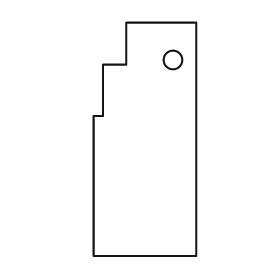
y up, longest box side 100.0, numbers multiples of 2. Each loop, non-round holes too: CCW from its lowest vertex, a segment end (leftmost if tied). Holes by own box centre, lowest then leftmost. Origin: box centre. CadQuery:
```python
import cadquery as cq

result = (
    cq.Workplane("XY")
    .moveTo(-22.0, -50.0)
    .lineTo(22.0, -50.0)
    .lineTo(22.0, 50.0)
    .lineTo(-8.0, 50.0)
    .lineTo(-8.0, 32.0)
    .lineTo(-18.0, 32.0)
    .lineTo(-18.0, 10.0)
    .lineTo(-22.0, 10.0)
    .close()
    .moveTo(12.0, 34.0)
    .circle(4.0)
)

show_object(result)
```